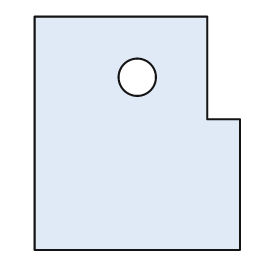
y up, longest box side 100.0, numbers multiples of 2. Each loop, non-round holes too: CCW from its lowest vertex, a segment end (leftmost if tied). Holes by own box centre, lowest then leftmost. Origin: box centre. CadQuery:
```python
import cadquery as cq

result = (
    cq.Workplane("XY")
    .moveTo(-44.0, -50.0)
    .lineTo(44.0, -50.0)
    .lineTo(44.0, 6.0)
    .lineTo(30.0, 6.0)
    .lineTo(30.0, 50.0)
    .lineTo(-44.0, 50.0)
    .close()
    .moveTo(0.0, 24.0)
    .circle(8.0)
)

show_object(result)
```